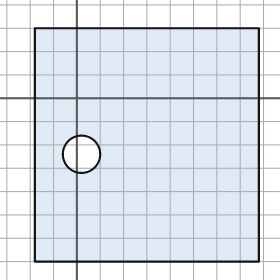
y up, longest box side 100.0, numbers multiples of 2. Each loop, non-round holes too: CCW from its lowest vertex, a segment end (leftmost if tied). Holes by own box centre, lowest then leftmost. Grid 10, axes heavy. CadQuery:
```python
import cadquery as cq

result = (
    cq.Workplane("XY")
    .moveTo(-18.0, -70.0)
    .lineTo(78.0, -70.0)
    .lineTo(78.0, 30.0)
    .lineTo(-18.0, 30.0)
    .close()
    .moveTo(2.0, -24.0)
    .circle(8.0)
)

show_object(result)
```